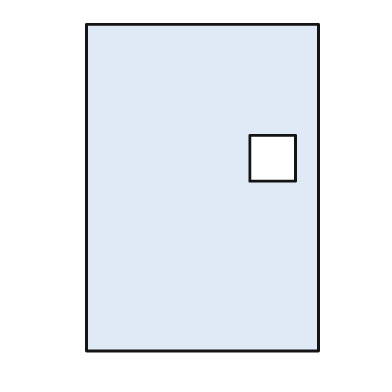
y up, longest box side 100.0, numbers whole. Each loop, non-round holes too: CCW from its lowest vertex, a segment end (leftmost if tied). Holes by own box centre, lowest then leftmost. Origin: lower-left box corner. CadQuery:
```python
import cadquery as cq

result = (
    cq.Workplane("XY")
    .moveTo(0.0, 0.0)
    .lineTo(71.0, 0.0)
    .lineTo(71.0, 100.0)
    .lineTo(0.0, 100.0)
    .close()
    .moveTo(50.0, 52.0)
    .lineTo(64.0, 52.0)
    .lineTo(64.0, 66.0)
    .lineTo(50.0, 66.0)
    .close()
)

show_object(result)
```